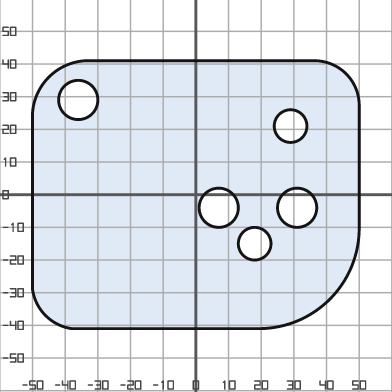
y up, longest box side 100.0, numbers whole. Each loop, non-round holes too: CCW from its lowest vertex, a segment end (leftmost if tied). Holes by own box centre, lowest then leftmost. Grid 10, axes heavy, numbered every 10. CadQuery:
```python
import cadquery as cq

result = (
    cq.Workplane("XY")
    .moveTo(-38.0, -41.0)
    .lineTo(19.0, -41.0)
    .threePointArc((41.0, -32.0), (50.0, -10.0))
    .lineTo(50.0, 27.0)
    .threePointArc((46.0, 37.0), (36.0, 41.0))
    .lineTo(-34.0, 41.0)
    .threePointArc((-45.0, 36.0), (-50.0, 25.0))
    .lineTo(-50.0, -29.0)
    .threePointArc((-46.0, -37.0), (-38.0, -41.0))
    .close()
    .moveTo(18.0, -15.0)
    .circle(5.0)
    .moveTo(7.0, -4.0)
    .circle(6.0)
    .moveTo(31.0, -4.0)
    .circle(6.0)
    .moveTo(29.0, 21.0)
    .circle(5.0)
    .moveTo(-36.0, 29.0)
    .circle(6.0)
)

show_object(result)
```